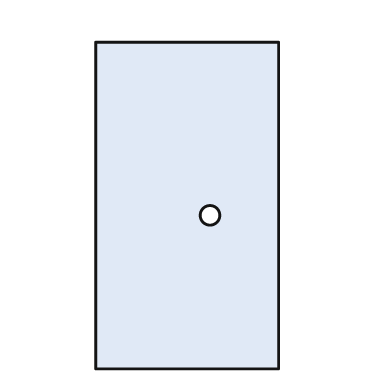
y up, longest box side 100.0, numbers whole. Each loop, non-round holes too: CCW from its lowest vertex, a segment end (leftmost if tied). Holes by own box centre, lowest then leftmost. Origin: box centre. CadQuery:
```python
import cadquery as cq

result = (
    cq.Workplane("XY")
    .moveTo(-28.0, -50.0)
    .lineTo(28.0, -50.0)
    .lineTo(28.0, 50.0)
    .lineTo(-28.0, 50.0)
    .close()
    .moveTo(7.0, -3.0)
    .circle(3.0)
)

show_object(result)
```